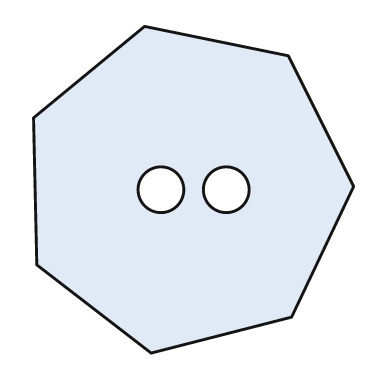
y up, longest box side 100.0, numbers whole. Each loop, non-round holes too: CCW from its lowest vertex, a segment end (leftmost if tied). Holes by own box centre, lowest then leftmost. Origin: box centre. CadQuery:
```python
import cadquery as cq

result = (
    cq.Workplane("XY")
    .moveTo(-13.0, -50.0)
    .lineTo(30.0, -39.0)
    .lineTo(49.0, 1.0)
    .lineTo(29.0, 41.0)
    .lineTo(-15.0, 50.0)
    .lineTo(-49.0, 22.0)
    .lineTo(-48.0, -23.0)
    .close()
    .moveTo(-10.0, 0.0)
    .circle(7.0)
    .moveTo(10.0, 0.0)
    .circle(7.0)
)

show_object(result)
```